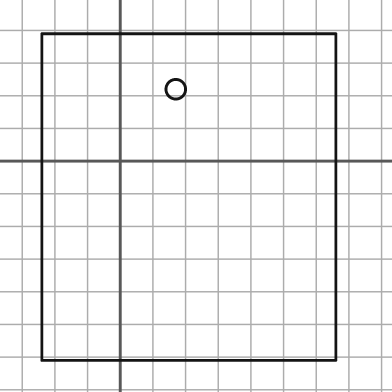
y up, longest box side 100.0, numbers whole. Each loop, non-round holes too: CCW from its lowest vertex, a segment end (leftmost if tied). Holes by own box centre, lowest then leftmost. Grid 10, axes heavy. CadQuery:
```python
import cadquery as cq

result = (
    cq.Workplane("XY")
    .moveTo(-24.0, -61.0)
    .lineTo(66.0, -61.0)
    .lineTo(66.0, 39.0)
    .lineTo(-24.0, 39.0)
    .close()
    .moveTo(17.0, 22.0)
    .circle(3.0)
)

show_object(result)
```